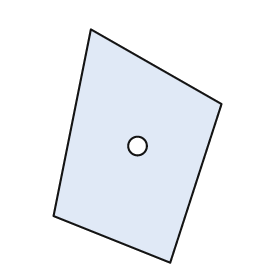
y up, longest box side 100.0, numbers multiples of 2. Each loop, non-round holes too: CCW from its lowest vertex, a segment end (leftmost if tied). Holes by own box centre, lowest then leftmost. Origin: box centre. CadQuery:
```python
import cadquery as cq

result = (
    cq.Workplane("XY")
    .moveTo(14.0, -50.0)
    .lineTo(36.0, 18.0)
    .lineTo(-20.0, 50.0)
    .lineTo(-36.0, -30.0)
    .close()
    .moveTo(0.0, 0.0)
    .circle(4.0)
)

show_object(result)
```